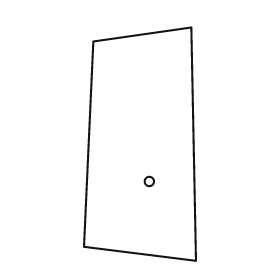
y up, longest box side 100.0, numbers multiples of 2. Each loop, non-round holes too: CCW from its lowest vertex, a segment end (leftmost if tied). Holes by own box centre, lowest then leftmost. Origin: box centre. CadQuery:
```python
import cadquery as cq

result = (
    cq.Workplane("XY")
    .moveTo(24.0, -50.0)
    .lineTo(22.0, 50.0)
    .lineTo(-20.0, 44.0)
    .lineTo(-24.0, -44.0)
    .close()
    .moveTo(4.0, -16.0)
    .circle(2.0)
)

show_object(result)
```